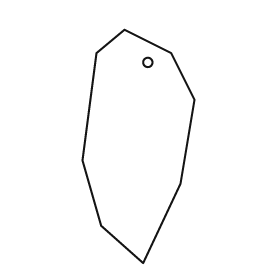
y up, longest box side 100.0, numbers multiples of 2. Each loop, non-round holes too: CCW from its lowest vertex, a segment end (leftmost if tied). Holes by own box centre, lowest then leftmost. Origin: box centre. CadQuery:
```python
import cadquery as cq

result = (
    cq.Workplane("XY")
    .moveTo(2.0, -50.0)
    .lineTo(18.0, -16.0)
    .lineTo(24.0, 20.0)
    .lineTo(14.0, 40.0)
    .lineTo(-6.0, 50.0)
    .lineTo(-18.0, 40.0)
    .lineTo(-24.0, -6.0)
    .lineTo(-16.0, -34.0)
    .close()
    .moveTo(4.0, 36.0)
    .circle(2.0)
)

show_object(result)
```